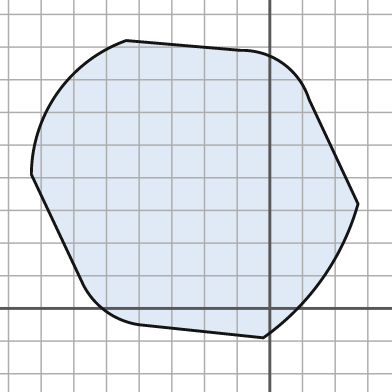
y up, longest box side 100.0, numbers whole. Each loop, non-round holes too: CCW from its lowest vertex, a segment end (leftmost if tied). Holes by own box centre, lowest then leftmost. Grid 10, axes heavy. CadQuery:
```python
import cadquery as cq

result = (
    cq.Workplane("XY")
    .moveTo(-2.0, -9.0)
    .threePointArc((16.0, 9.0), (27.0, 32.0))
    .lineTo(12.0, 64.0)
    .threePointArc((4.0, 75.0), (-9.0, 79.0))
    .lineTo(-44.0, 82.0)
    .threePointArc((-65.0, 66.0), (-73.0, 41.0))
    .lineTo(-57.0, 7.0)
    .threePointArc((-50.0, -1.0), (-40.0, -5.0))
    .close()
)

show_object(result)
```